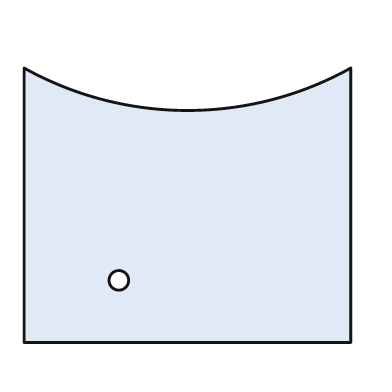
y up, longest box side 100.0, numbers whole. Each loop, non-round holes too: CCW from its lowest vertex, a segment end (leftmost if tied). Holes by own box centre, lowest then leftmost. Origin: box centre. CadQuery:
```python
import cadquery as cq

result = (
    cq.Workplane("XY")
    .moveTo(-50.0, -42.0)
    .lineTo(50.0, -42.0)
    .lineTo(50.0, 42.0)
    .threePointArc((0.0, 29.0), (-50.0, 42.0))
    .close()
    .moveTo(-21.0, -23.0)
    .circle(3.0)
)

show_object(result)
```